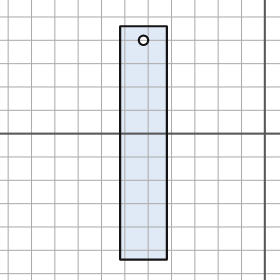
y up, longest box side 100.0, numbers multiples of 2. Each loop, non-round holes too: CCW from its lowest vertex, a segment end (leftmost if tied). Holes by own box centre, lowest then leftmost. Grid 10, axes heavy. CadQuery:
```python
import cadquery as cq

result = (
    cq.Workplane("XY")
    .moveTo(-62.0, -54.0)
    .lineTo(-42.0, -54.0)
    .lineTo(-42.0, 46.0)
    .lineTo(-62.0, 46.0)
    .close()
    .moveTo(-52.0, 40.0)
    .circle(2.0)
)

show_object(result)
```